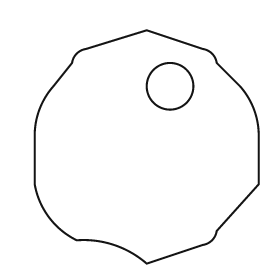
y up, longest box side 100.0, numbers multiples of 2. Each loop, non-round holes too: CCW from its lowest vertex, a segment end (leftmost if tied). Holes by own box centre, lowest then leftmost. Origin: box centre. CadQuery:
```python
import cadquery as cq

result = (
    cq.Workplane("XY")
    .moveTo(0.0, -50.0)
    .lineTo(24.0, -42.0)
    .threePointArc((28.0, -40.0), (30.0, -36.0))
    .lineTo(48.0, -16.0)
    .lineTo(48.0, 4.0)
    .threePointArc((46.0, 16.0), (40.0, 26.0))
    .lineTo(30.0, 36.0)
    .threePointArc((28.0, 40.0), (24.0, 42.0))
    .lineTo(0.0, 50.0)
    .lineTo(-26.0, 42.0)
    .threePointArc((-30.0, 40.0), (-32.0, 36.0))
    .lineTo(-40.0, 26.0)
    .threePointArc((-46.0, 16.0), (-48.0, 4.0))
    .lineTo(-48.0, -16.0)
    .threePointArc((-42.0, -30.0), (-30.0, -40.0))
    .threePointArc((-14.0, -42.0), (0.0, -50.0))
    .close()
    .moveTo(10.0, 26.0)
    .circle(10.0)
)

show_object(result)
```